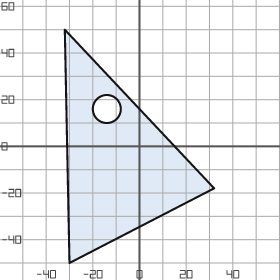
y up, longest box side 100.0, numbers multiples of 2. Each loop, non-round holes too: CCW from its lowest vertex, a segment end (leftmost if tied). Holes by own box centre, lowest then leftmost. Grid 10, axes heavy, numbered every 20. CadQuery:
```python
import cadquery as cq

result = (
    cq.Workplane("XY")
    .moveTo(-30.0, -50.0)
    .lineTo(32.0, -18.0)
    .lineTo(-32.0, 50.0)
    .close()
    .moveTo(-14.0, 16.0)
    .circle(6.0)
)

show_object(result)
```